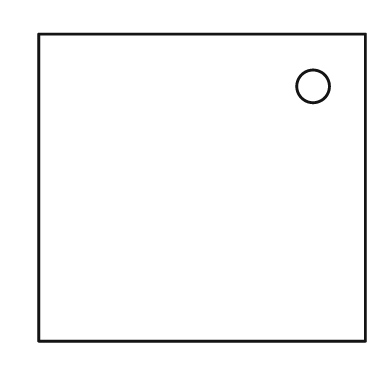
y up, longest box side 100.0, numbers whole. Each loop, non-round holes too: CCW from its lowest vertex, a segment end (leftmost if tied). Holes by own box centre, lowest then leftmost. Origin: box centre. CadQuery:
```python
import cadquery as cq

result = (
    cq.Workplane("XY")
    .moveTo(-50.0, -47.0)
    .lineTo(50.0, -47.0)
    .lineTo(50.0, 47.0)
    .lineTo(-50.0, 47.0)
    .close()
    .moveTo(34.0, 31.0)
    .circle(5.0)
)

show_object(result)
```